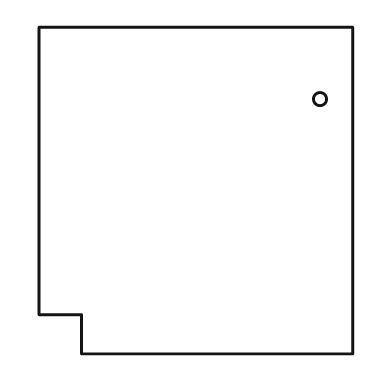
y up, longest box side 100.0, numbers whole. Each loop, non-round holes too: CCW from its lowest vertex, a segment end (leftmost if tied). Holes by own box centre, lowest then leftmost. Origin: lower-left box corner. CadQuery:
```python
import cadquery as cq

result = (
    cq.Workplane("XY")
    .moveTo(13.0, 0.0)
    .lineTo(96.0, 0.0)
    .lineTo(96.0, 100.0)
    .lineTo(0.0, 100.0)
    .lineTo(0.0, 12.0)
    .lineTo(13.0, 12.0)
    .close()
    .moveTo(86.0, 78.0)
    .circle(2.0)
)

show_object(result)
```